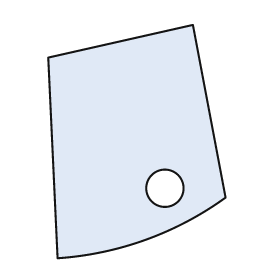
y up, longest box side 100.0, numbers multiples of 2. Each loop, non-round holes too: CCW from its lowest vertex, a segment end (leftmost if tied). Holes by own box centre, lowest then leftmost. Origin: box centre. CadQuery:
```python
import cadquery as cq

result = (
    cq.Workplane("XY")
    .moveTo(-34.0, -50.0)
    .threePointArc((4.0, -42.0), (38.0, -24.0))
    .lineTo(24.0, 50.0)
    .lineTo(-38.0, 36.0)
    .close()
    .moveTo(12.0, -20.0)
    .circle(8.0)
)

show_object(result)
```